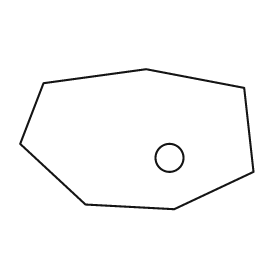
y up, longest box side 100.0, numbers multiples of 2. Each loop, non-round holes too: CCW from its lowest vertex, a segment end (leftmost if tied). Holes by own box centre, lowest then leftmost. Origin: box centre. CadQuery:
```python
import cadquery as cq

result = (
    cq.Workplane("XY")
    .moveTo(16.0, -30.0)
    .lineTo(50.0, -14.0)
    .lineTo(46.0, 22.0)
    .lineTo(4.0, 30.0)
    .lineTo(-40.0, 24.0)
    .lineTo(-50.0, -2.0)
    .lineTo(-22.0, -28.0)
    .close()
    .moveTo(14.0, -8.0)
    .circle(6.0)
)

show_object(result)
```